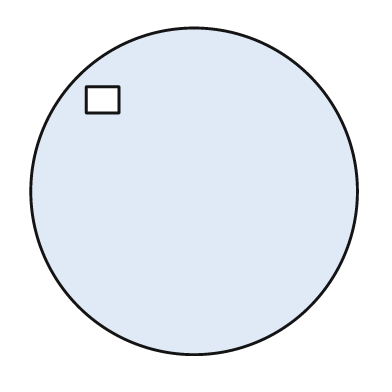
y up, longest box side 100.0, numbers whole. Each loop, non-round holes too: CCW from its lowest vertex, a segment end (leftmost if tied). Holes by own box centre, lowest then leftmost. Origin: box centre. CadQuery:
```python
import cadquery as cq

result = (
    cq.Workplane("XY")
    .moveTo(0.0, 0.0)
    .circle(50.0)
    .moveTo(-33.0, 24.0)
    .lineTo(-23.0, 24.0)
    .lineTo(-23.0, 32.0)
    .lineTo(-33.0, 32.0)
    .close()
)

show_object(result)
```